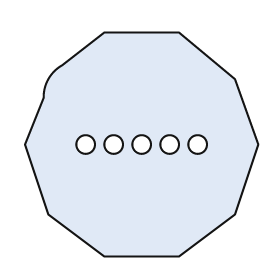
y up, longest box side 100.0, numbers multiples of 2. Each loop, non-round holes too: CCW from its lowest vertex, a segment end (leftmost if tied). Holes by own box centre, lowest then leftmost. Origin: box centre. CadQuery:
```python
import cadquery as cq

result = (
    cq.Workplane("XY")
    .moveTo(-16.0, -48.0)
    .lineTo(16.0, -48.0)
    .lineTo(40.0, -30.0)
    .lineTo(50.0, 0.0)
    .lineTo(40.0, 28.0)
    .lineTo(16.0, 48.0)
    .lineTo(-16.0, 48.0)
    .lineTo(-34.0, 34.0)
    .threePointArc((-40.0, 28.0), (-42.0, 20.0))
    .lineTo(-50.0, 0.0)
    .lineTo(-40.0, -30.0)
    .close()
    .moveTo(-24.0, 0.0)
    .circle(4.0)
    .moveTo(-12.0, 0.0)
    .circle(4.0)
    .moveTo(0.0, 0.0)
    .circle(4.0)
    .moveTo(12.0, 0.0)
    .circle(4.0)
    .moveTo(24.0, 0.0)
    .circle(4.0)
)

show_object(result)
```